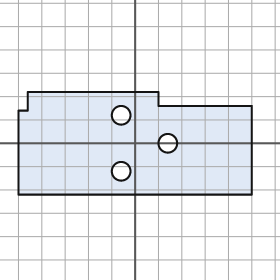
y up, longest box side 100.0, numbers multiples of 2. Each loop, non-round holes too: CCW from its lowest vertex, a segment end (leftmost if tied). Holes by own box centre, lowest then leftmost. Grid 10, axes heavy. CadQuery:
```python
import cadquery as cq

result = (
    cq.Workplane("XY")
    .moveTo(-50.0, -22.0)
    .lineTo(50.0, -22.0)
    .lineTo(50.0, 16.0)
    .lineTo(10.0, 16.0)
    .lineTo(10.0, 22.0)
    .lineTo(-46.0, 22.0)
    .lineTo(-46.0, 14.0)
    .lineTo(-50.0, 14.0)
    .close()
    .moveTo(-6.0, -12.0)
    .circle(4.0)
    .moveTo(14.0, 0.0)
    .circle(4.0)
    .moveTo(-6.0, 12.0)
    .circle(4.0)
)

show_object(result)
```